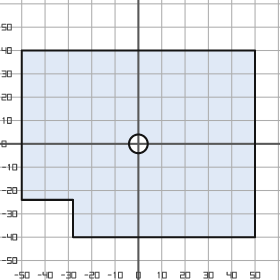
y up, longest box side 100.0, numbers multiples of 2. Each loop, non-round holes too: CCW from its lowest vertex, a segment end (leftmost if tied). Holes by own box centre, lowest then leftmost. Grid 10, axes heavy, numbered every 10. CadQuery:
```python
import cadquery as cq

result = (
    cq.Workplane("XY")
    .moveTo(-28.0, -40.0)
    .lineTo(50.0, -40.0)
    .lineTo(50.0, 40.0)
    .lineTo(-50.0, 40.0)
    .lineTo(-50.0, -24.0)
    .lineTo(-28.0, -24.0)
    .close()
    .moveTo(0.0, 0.0)
    .circle(4.0)
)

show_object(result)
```